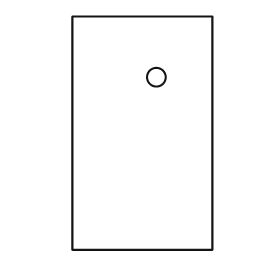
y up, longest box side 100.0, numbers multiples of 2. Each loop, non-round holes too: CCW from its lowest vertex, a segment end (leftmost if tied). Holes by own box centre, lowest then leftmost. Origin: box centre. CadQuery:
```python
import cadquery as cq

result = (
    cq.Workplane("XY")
    .moveTo(-30.0, -50.0)
    .lineTo(30.0, -50.0)
    .lineTo(30.0, 50.0)
    .lineTo(-30.0, 50.0)
    .close()
    .moveTo(6.0, 24.0)
    .circle(4.0)
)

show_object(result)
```